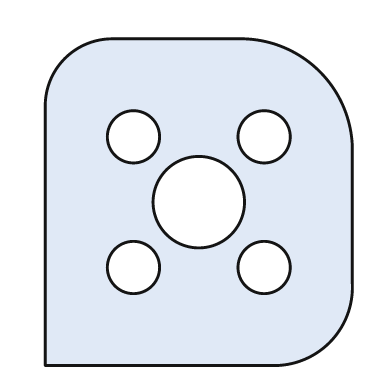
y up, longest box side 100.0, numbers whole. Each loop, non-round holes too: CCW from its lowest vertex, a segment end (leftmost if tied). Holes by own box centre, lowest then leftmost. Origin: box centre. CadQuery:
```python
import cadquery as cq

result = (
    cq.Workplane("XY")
    .moveTo(-47.0, -50.0)
    .lineTo(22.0, -50.0)
    .threePointArc((40.0, -43.0), (47.0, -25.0))
    .lineTo(47.0, 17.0)
    .threePointArc((37.0, 40.0), (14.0, 50.0))
    .lineTo(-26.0, 50.0)
    .threePointArc((-41.0, 44.0), (-47.0, 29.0))
    .close()
    .moveTo(-20.0, -20.0)
    .circle(8.0)
    .moveTo(20.0, -20.0)
    .circle(8.0)
    .moveTo(0.0, 0.0)
    .circle(14.0)
    .moveTo(-20.0, 20.0)
    .circle(8.0)
    .moveTo(20.0, 20.0)
    .circle(8.0)
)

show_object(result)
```